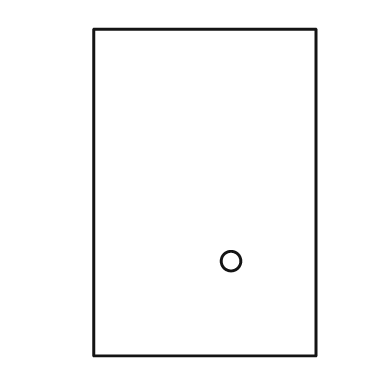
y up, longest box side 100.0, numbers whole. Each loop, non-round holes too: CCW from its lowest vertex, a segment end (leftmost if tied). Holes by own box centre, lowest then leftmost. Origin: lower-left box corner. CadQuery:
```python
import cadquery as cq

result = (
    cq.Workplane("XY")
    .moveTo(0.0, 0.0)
    .lineTo(68.0, 0.0)
    .lineTo(68.0, 100.0)
    .lineTo(0.0, 100.0)
    .close()
    .moveTo(42.0, 29.0)
    .circle(3.0)
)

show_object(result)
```